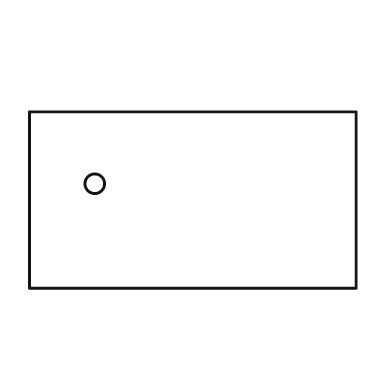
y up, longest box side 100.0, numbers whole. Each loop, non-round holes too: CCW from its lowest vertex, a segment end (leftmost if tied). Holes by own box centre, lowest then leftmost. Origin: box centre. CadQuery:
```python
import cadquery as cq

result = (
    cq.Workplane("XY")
    .moveTo(-50.0, -27.0)
    .lineTo(50.0, -27.0)
    .lineTo(50.0, 27.0)
    .lineTo(-50.0, 27.0)
    .close()
    .moveTo(-30.0, 5.0)
    .circle(3.0)
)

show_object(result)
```